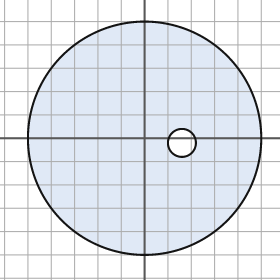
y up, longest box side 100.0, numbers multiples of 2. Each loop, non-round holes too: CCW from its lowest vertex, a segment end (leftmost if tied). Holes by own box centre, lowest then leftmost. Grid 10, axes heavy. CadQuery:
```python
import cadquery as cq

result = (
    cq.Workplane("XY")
    .moveTo(0.0, 0.0)
    .circle(50.0)
    .moveTo(16.0, -2.0)
    .circle(6.0)
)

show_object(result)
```